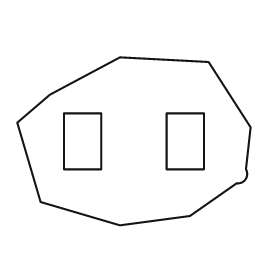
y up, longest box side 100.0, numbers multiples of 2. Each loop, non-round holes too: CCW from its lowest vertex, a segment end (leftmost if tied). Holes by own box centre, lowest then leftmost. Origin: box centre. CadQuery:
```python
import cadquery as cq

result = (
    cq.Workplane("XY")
    .moveTo(-6.0, -36.0)
    .lineTo(24.0, -32.0)
    .lineTo(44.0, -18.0)
    .threePointArc((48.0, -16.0), (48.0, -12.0))
    .lineTo(50.0, 6.0)
    .lineTo(32.0, 34.0)
    .lineTo(-6.0, 36.0)
    .lineTo(-36.0, 20.0)
    .lineTo(-50.0, 8.0)
    .lineTo(-40.0, -26.0)
    .close()
    .moveTo(-30.0, -12.0)
    .lineTo(-14.0, -12.0)
    .lineTo(-14.0, 12.0)
    .lineTo(-30.0, 12.0)
    .close()
    .moveTo(14.0, -12.0)
    .lineTo(30.0, -12.0)
    .lineTo(30.0, 12.0)
    .lineTo(14.0, 12.0)
    .close()
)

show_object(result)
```